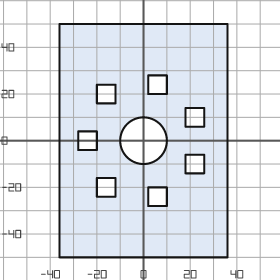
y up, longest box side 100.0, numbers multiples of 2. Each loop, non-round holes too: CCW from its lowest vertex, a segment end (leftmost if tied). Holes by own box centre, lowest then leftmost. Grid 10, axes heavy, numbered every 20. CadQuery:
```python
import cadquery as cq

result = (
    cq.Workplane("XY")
    .moveTo(-36.0, -50.0)
    .lineTo(36.0, -50.0)
    .lineTo(36.0, 50.0)
    .lineTo(-36.0, 50.0)
    .close()
    .moveTo(2.0, -28.0)
    .lineTo(10.0, -28.0)
    .lineTo(10.0, -20.0)
    .lineTo(2.0, -20.0)
    .close()
    .moveTo(-20.0, -24.0)
    .lineTo(-12.0, -24.0)
    .lineTo(-12.0, -16.0)
    .lineTo(-20.0, -16.0)
    .close()
    .moveTo(18.0, -14.0)
    .lineTo(26.0, -14.0)
    .lineTo(26.0, -6.0)
    .lineTo(18.0, -6.0)
    .close()
    .moveTo(-28.0, -4.0)
    .lineTo(-20.0, -4.0)
    .lineTo(-20.0, 4.0)
    .lineTo(-28.0, 4.0)
    .close()
    .moveTo(0.0, 0.0)
    .circle(10.0)
    .moveTo(18.0, 6.0)
    .lineTo(26.0, 6.0)
    .lineTo(26.0, 14.0)
    .lineTo(18.0, 14.0)
    .close()
    .moveTo(-20.0, 16.0)
    .lineTo(-12.0, 16.0)
    .lineTo(-12.0, 24.0)
    .lineTo(-20.0, 24.0)
    .close()
    .moveTo(2.0, 20.0)
    .lineTo(10.0, 20.0)
    .lineTo(10.0, 28.0)
    .lineTo(2.0, 28.0)
    .close()
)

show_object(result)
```